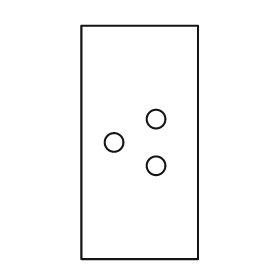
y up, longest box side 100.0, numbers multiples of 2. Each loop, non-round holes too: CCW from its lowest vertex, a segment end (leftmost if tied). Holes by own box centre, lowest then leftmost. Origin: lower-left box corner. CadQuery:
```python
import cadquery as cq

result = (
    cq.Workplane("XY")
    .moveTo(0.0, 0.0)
    .lineTo(50.0, 0.0)
    .lineTo(50.0, 100.0)
    .lineTo(0.0, 100.0)
    .close()
    .moveTo(32.0, 40.0)
    .circle(4.0)
    .moveTo(14.0, 50.0)
    .circle(4.0)
    .moveTo(32.0, 60.0)
    .circle(4.0)
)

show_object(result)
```